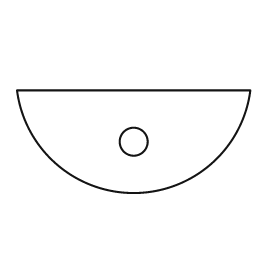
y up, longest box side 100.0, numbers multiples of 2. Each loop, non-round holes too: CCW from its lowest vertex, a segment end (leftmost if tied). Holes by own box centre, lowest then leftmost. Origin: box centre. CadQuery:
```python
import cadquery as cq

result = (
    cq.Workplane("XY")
    .moveTo(-50.0, 22.0)
    .threePointArc((0.0, -22.0), (50.0, 22.0))
    .close()
    .moveTo(0.0, 0.0)
    .circle(6.0)
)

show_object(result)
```